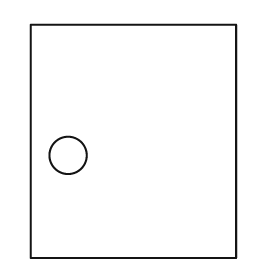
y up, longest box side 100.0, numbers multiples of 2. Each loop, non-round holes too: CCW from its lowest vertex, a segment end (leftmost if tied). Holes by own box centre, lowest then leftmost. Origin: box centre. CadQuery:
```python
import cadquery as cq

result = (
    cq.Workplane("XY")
    .moveTo(-44.0, -50.0)
    .lineTo(44.0, -50.0)
    .lineTo(44.0, 50.0)
    .lineTo(-44.0, 50.0)
    .close()
    .moveTo(-28.0, -6.0)
    .circle(8.0)
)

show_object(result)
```